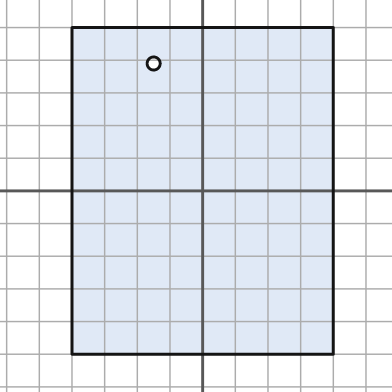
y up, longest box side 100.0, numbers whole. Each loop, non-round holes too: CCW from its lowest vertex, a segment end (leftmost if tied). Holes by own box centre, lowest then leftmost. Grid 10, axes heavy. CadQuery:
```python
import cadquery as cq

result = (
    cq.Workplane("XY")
    .moveTo(-40.0, -50.0)
    .lineTo(40.0, -50.0)
    .lineTo(40.0, 50.0)
    .lineTo(-40.0, 50.0)
    .close()
    .moveTo(-15.0, 39.0)
    .circle(2.0)
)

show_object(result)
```